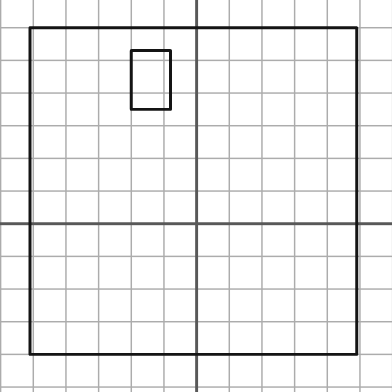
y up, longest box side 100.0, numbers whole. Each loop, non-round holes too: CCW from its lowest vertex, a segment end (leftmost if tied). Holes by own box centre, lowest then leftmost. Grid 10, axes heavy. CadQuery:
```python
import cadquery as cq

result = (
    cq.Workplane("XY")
    .moveTo(-51.0, -40.0)
    .lineTo(49.0, -40.0)
    .lineTo(49.0, 60.0)
    .lineTo(-51.0, 60.0)
    .close()
    .moveTo(-20.0, 35.0)
    .lineTo(-8.0, 35.0)
    .lineTo(-8.0, 53.0)
    .lineTo(-20.0, 53.0)
    .close()
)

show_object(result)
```